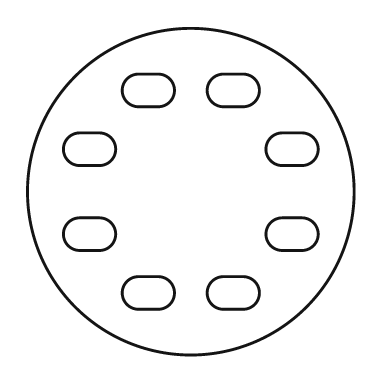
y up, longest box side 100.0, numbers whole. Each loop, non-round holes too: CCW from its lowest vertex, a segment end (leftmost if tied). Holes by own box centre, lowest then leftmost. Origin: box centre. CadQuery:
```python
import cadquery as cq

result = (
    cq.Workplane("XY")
    .moveTo(0.0, 0.0)
    .circle(50.0)
    .moveTo(-16.0, -36.0)
    .lineTo(-10.0, -36.0)
    .threePointArc((-5.0, -31.0), (-10.0, -26.0))
    .lineTo(-16.0, -26.0)
    .threePointArc((-21.0, -31.0), (-16.0, -36.0))
    .close()
    .moveTo(10.0, -36.0)
    .lineTo(16.0, -36.0)
    .threePointArc((21.0, -31.0), (16.0, -26.0))
    .lineTo(10.0, -26.0)
    .threePointArc((5.0, -31.0), (10.0, -36.0))
    .close()
    .moveTo(-34.0, -18.0)
    .lineTo(-28.0, -18.0)
    .threePointArc((-23.0, -13.0), (-28.0, -8.0))
    .lineTo(-34.0, -8.0)
    .threePointArc((-39.0, -13.0), (-34.0, -18.0))
    .close()
    .moveTo(28.0, -18.0)
    .lineTo(34.0, -18.0)
    .threePointArc((39.0, -13.0), (34.0, -8.0))
    .lineTo(28.0, -8.0)
    .threePointArc((23.0, -13.0), (28.0, -18.0))
    .close()
    .moveTo(-34.0, 8.0)
    .lineTo(-28.0, 8.0)
    .threePointArc((-23.0, 13.0), (-28.0, 18.0))
    .lineTo(-34.0, 18.0)
    .threePointArc((-39.0, 13.0), (-34.0, 8.0))
    .close()
    .moveTo(28.0, 8.0)
    .lineTo(34.0, 8.0)
    .threePointArc((39.0, 13.0), (34.0, 18.0))
    .lineTo(28.0, 18.0)
    .threePointArc((23.0, 13.0), (28.0, 8.0))
    .close()
    .moveTo(-16.0, 26.0)
    .lineTo(-10.0, 26.0)
    .threePointArc((-5.0, 31.0), (-10.0, 36.0))
    .lineTo(-16.0, 36.0)
    .threePointArc((-21.0, 31.0), (-16.0, 26.0))
    .close()
    .moveTo(10.0, 26.0)
    .lineTo(16.0, 26.0)
    .threePointArc((21.0, 31.0), (16.0, 36.0))
    .lineTo(10.0, 36.0)
    .threePointArc((5.0, 31.0), (10.0, 26.0))
    .close()
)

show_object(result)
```